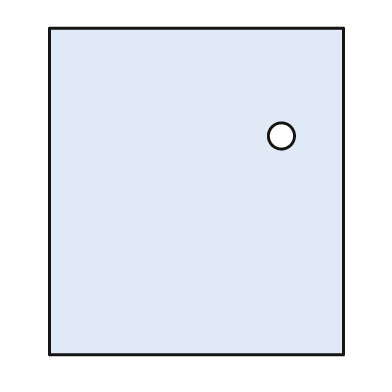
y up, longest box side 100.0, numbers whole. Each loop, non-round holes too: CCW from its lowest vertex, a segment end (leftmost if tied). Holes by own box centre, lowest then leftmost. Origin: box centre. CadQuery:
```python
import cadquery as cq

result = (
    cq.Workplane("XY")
    .moveTo(-45.0, -50.0)
    .lineTo(45.0, -50.0)
    .lineTo(45.0, 50.0)
    .lineTo(-45.0, 50.0)
    .close()
    .moveTo(26.0, 17.0)
    .circle(4.0)
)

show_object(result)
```